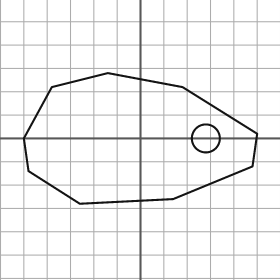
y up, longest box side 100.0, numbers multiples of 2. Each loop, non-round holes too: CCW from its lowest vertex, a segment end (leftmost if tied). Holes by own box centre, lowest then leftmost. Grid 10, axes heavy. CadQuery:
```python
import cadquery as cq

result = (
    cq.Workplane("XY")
    .moveTo(-26.0, -28.0)
    .lineTo(14.0, -26.0)
    .lineTo(48.0, -12.0)
    .lineTo(50.0, 2.0)
    .lineTo(18.0, 22.0)
    .lineTo(-14.0, 28.0)
    .lineTo(-38.0, 22.0)
    .lineTo(-50.0, 0.0)
    .lineTo(-48.0, -14.0)
    .close()
    .moveTo(28.0, 0.0)
    .circle(6.0)
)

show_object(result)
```